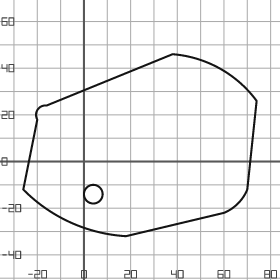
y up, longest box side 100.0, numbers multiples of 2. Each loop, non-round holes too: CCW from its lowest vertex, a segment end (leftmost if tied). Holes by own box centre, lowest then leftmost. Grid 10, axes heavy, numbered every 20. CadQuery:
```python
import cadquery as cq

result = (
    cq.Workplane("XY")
    .moveTo(18.0, -32.0)
    .lineTo(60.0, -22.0)
    .threePointArc((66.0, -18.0), (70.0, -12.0))
    .lineTo(74.0, 26.0)
    .threePointArc((58.0, 40.0), (38.0, 46.0))
    .lineTo(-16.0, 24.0)
    .threePointArc((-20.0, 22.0), (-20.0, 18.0))
    .lineTo(-26.0, -12.0)
    .threePointArc((-6.0, -26.0), (18.0, -32.0))
    .close()
    .moveTo(4.0, -14.0)
    .circle(4.0)
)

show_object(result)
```